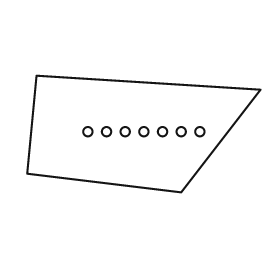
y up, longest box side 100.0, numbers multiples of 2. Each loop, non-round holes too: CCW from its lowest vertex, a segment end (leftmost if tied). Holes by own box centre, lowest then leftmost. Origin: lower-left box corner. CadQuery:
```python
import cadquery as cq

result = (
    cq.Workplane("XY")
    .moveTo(66.0, 0.0)
    .lineTo(100.0, 44.0)
    .lineTo(4.0, 50.0)
    .lineTo(0.0, 8.0)
    .close()
    .moveTo(26.0, 26.0)
    .circle(2.0)
    .moveTo(34.0, 26.0)
    .circle(2.0)
    .moveTo(42.0, 26.0)
    .circle(2.0)
    .moveTo(50.0, 26.0)
    .circle(2.0)
    .moveTo(58.0, 26.0)
    .circle(2.0)
    .moveTo(66.0, 26.0)
    .circle(2.0)
    .moveTo(74.0, 26.0)
    .circle(2.0)
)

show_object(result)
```